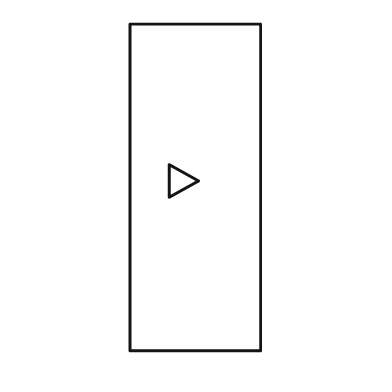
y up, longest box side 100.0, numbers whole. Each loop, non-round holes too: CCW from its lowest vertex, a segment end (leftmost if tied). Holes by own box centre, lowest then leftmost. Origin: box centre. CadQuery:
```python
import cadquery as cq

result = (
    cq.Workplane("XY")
    .moveTo(-20.0, -50.0)
    .lineTo(20.0, -50.0)
    .lineTo(20.0, 50.0)
    .lineTo(-20.0, 50.0)
    .close()
    .moveTo(-8.0, -3.0)
    .lineTo(1.0, 2.0)
    .lineTo(-8.0, 7.0)
    .close()
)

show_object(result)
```